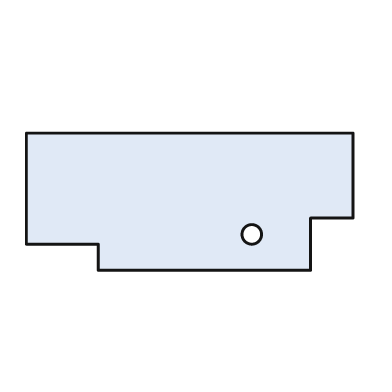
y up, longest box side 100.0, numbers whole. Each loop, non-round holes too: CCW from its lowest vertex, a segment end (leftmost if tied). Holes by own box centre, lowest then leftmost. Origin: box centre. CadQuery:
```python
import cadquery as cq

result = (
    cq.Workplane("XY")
    .moveTo(-28.0, -21.0)
    .lineTo(37.0, -21.0)
    .lineTo(37.0, -5.0)
    .lineTo(50.0, -5.0)
    .lineTo(50.0, 21.0)
    .lineTo(-50.0, 21.0)
    .lineTo(-50.0, -13.0)
    .lineTo(-28.0, -13.0)
    .close()
    .moveTo(19.0, -10.0)
    .circle(3.0)
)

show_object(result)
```